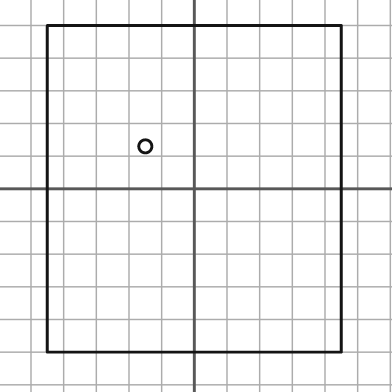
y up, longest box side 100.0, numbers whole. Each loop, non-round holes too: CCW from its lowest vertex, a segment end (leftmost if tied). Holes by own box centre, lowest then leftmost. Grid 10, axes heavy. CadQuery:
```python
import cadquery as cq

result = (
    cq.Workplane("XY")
    .moveTo(-45.0, -50.0)
    .lineTo(45.0, -50.0)
    .lineTo(45.0, 50.0)
    .lineTo(-45.0, 50.0)
    .close()
    .moveTo(-15.0, 13.0)
    .circle(2.0)
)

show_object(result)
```